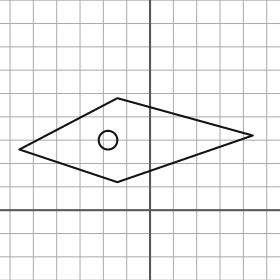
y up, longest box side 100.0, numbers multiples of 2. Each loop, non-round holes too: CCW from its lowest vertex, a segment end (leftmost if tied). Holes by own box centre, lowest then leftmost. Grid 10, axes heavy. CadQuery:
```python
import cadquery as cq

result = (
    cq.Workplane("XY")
    .moveTo(-14.0, 12.0)
    .lineTo(44.0, 32.0)
    .lineTo(-14.0, 48.0)
    .lineTo(-56.0, 26.0)
    .close()
    .moveTo(-18.0, 30.0)
    .circle(4.0)
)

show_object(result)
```